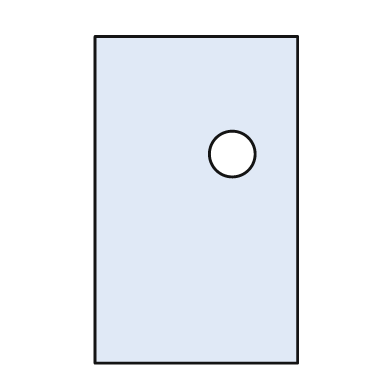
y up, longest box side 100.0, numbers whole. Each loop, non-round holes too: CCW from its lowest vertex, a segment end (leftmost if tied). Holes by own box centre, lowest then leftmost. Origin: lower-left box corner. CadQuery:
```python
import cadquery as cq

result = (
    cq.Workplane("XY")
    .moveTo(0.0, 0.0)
    .lineTo(62.0, 0.0)
    .lineTo(62.0, 100.0)
    .lineTo(0.0, 100.0)
    .close()
    .moveTo(42.0, 64.0)
    .circle(7.0)
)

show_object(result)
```